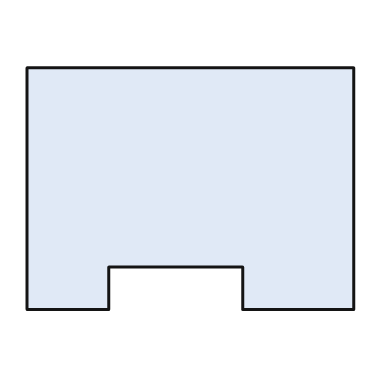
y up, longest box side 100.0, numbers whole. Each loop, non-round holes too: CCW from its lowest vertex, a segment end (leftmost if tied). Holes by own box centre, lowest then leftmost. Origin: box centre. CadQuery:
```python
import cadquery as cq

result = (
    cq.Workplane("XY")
    .moveTo(-50.0, -37.0)
    .lineTo(-25.0, -37.0)
    .lineTo(-25.0, -24.0)
    .lineTo(16.0, -24.0)
    .lineTo(16.0, -37.0)
    .lineTo(50.0, -37.0)
    .lineTo(50.0, 37.0)
    .lineTo(-50.0, 37.0)
    .close()
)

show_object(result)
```